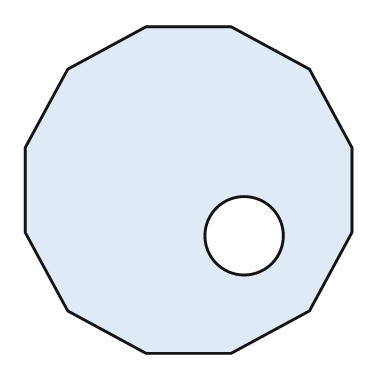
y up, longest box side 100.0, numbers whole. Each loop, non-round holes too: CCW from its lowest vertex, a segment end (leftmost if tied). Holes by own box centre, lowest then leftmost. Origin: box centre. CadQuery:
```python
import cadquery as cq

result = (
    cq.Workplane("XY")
    .moveTo(-13.0, -50.0)
    .lineTo(13.0, -50.0)
    .lineTo(37.0, -37.0)
    .lineTo(50.0, -13.0)
    .lineTo(50.0, 13.0)
    .lineTo(37.0, 37.0)
    .lineTo(13.0, 50.0)
    .lineTo(-13.0, 50.0)
    .lineTo(-37.0, 37.0)
    .lineTo(-50.0, 13.0)
    .lineTo(-50.0, -13.0)
    .lineTo(-37.0, -37.0)
    .close()
    .moveTo(17.0, -14.0)
    .circle(12.0)
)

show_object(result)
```